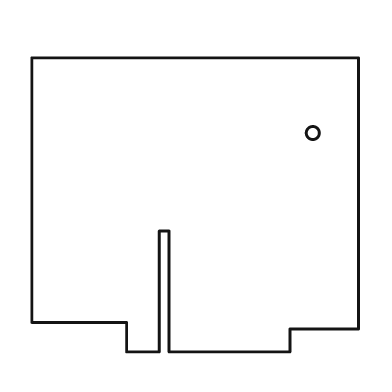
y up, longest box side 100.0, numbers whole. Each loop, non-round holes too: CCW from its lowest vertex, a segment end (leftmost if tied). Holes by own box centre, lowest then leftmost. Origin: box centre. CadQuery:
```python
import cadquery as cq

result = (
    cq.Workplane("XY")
    .moveTo(-21.0, -45.0)
    .lineTo(-11.0, -45.0)
    .lineTo(-11.0, -8.0)
    .lineTo(-8.0, -8.0)
    .lineTo(-8.0, -45.0)
    .lineTo(29.0, -45.0)
    .lineTo(29.0, -38.0)
    .lineTo(50.0, -38.0)
    .lineTo(50.0, 45.0)
    .lineTo(-50.0, 45.0)
    .lineTo(-50.0, -36.0)
    .lineTo(-21.0, -36.0)
    .close()
    .moveTo(36.0, 22.0)
    .circle(2.0)
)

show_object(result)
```